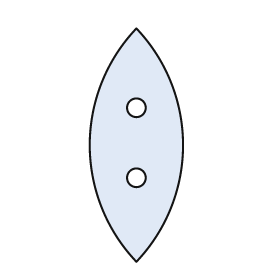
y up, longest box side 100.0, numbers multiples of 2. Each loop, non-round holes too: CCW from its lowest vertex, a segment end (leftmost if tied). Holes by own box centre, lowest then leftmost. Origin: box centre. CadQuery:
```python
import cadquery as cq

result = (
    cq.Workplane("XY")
    .moveTo(0.0, -50.0)
    .threePointArc((20.0, 0.0), (0.0, 50.0))
    .threePointArc((-20.0, 0.0), (0.0, -50.0))
    .close()
    .moveTo(0.0, -14.0)
    .circle(4.0)
    .moveTo(0.0, 16.0)
    .circle(4.0)
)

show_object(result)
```